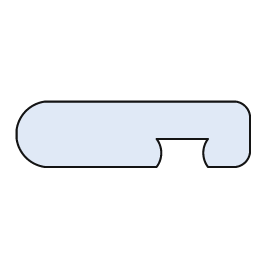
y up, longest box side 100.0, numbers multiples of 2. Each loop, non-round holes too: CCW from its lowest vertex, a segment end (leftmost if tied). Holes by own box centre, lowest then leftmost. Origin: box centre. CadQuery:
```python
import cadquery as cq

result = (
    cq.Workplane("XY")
    .moveTo(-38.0, -14.0)
    .lineTo(10.0, -14.0)
    .threePointArc((12.0, -8.0), (10.0, -2.0))
    .lineTo(32.0, -2.0)
    .threePointArc((30.0, -8.0), (32.0, -14.0))
    .lineTo(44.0, -14.0)
    .threePointArc((48.0, -12.0), (50.0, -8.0))
    .lineTo(50.0, 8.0)
    .threePointArc((48.0, 12.0), (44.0, 14.0))
    .lineTo(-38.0, 14.0)
    .threePointArc((-46.0, 10.0), (-50.0, 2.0))
    .lineTo(-50.0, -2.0)
    .threePointArc((-46.0, -10.0), (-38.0, -14.0))
    .close()
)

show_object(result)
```